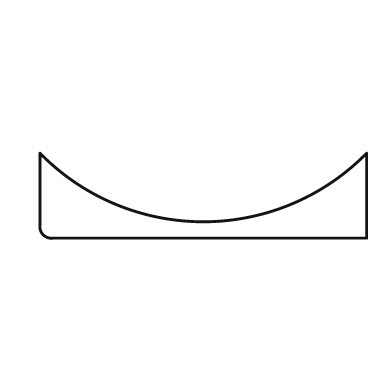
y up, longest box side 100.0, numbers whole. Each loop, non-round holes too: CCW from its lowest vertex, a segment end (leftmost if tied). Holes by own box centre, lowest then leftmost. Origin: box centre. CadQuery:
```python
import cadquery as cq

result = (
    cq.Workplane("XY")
    .moveTo(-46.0, -13.0)
    .lineTo(50.0, -13.0)
    .lineTo(50.0, 13.0)
    .threePointArc((0.0, -8.0), (-50.0, 13.0))
    .lineTo(-50.0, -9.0)
    .threePointArc((-49.0, -12.0), (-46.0, -13.0))
    .close()
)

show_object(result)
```